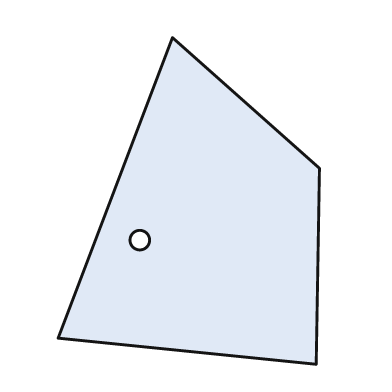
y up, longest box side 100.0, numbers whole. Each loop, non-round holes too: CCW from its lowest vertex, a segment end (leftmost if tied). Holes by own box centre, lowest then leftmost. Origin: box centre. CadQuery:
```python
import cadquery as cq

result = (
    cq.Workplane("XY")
    .moveTo(39.0, -50.0)
    .lineTo(40.0, 10.0)
    .lineTo(-5.0, 50.0)
    .lineTo(-40.0, -42.0)
    .close()
    .moveTo(-15.0, -12.0)
    .circle(3.0)
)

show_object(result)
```